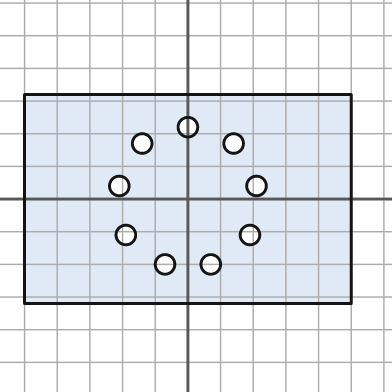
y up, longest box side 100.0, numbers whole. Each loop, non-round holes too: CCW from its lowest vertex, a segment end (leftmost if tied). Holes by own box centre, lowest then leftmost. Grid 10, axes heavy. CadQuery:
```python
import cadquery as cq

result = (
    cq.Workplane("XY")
    .moveTo(-50.0, -32.0)
    .lineTo(50.0, -32.0)
    .lineTo(50.0, 32.0)
    .lineTo(-50.0, 32.0)
    .close()
    .moveTo(-7.0, -20.0)
    .circle(3.0)
    .moveTo(7.0, -20.0)
    .circle(3.0)
    .moveTo(-19.0, -11.0)
    .circle(3.0)
    .moveTo(19.0, -11.0)
    .circle(3.0)
    .moveTo(-21.0, 4.0)
    .circle(3.0)
    .moveTo(21.0, 4.0)
    .circle(3.0)
    .moveTo(-14.0, 17.0)
    .circle(3.0)
    .moveTo(14.0, 17.0)
    .circle(3.0)
    .moveTo(0.0, 22.0)
    .circle(3.0)
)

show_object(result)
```